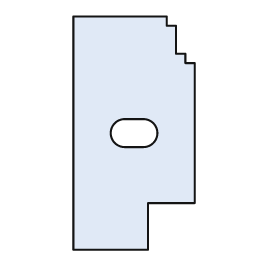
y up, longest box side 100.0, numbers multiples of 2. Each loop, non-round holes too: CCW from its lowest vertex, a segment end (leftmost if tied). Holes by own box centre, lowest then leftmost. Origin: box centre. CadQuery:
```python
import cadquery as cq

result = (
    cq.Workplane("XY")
    .moveTo(-26.0, -50.0)
    .lineTo(6.0, -50.0)
    .lineTo(6.0, -30.0)
    .lineTo(26.0, -30.0)
    .lineTo(26.0, 30.0)
    .lineTo(22.0, 30.0)
    .lineTo(22.0, 34.0)
    .lineTo(18.0, 34.0)
    .lineTo(18.0, 46.0)
    .lineTo(14.0, 46.0)
    .lineTo(14.0, 50.0)
    .lineTo(-26.0, 50.0)
    .close()
    .moveTo(-4.0, -6.0)
    .lineTo(4.0, -6.0)
    .threePointArc((10.0, 0.0), (4.0, 6.0))
    .lineTo(-4.0, 6.0)
    .threePointArc((-10.0, 0.0), (-4.0, -6.0))
    .close()
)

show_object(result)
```